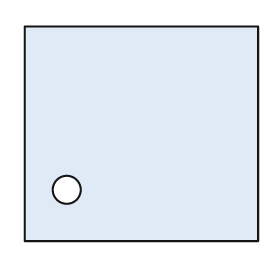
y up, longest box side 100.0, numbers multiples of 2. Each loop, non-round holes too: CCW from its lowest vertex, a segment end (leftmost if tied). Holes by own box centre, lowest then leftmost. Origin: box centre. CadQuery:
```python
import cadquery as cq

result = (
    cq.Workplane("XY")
    .moveTo(-50.0, -46.0)
    .lineTo(50.0, -46.0)
    .lineTo(50.0, 46.0)
    .lineTo(-50.0, 46.0)
    .close()
    .moveTo(-32.0, -24.0)
    .circle(6.0)
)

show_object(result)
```